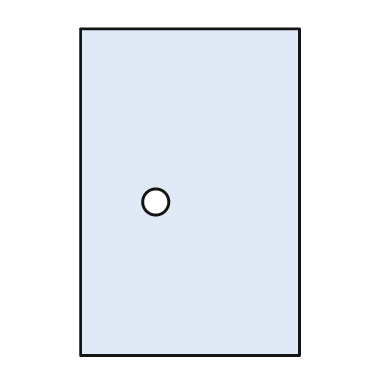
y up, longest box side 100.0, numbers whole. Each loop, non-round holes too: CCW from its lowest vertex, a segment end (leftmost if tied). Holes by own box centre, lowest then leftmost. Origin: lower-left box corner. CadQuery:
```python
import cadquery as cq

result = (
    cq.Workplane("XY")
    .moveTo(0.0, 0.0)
    .lineTo(67.0, 0.0)
    .lineTo(67.0, 100.0)
    .lineTo(0.0, 100.0)
    .close()
    .moveTo(23.0, 47.0)
    .circle(4.0)
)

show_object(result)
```